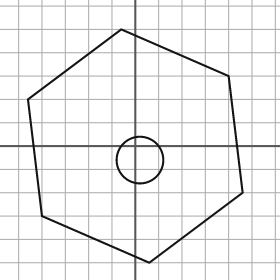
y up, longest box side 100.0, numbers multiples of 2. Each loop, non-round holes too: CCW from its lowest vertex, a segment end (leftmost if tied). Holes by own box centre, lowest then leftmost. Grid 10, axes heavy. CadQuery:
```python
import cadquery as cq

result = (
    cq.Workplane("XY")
    .moveTo(6.0, -50.0)
    .lineTo(46.0, -20.0)
    .lineTo(40.0, 30.0)
    .lineTo(-6.0, 50.0)
    .lineTo(-46.0, 20.0)
    .lineTo(-40.0, -30.0)
    .close()
    .moveTo(2.0, -6.0)
    .circle(10.0)
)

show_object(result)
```